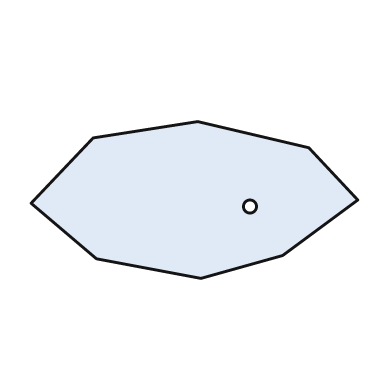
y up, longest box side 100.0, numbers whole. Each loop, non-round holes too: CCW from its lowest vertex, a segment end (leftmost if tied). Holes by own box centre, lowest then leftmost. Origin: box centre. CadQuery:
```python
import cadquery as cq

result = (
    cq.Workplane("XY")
    .moveTo(2.0, -24.0)
    .lineTo(27.0, -17.0)
    .lineTo(50.0, 0.0)
    .lineTo(35.0, 16.0)
    .lineTo(1.0, 24.0)
    .lineTo(-31.0, 19.0)
    .lineTo(-50.0, -1.0)
    .lineTo(-30.0, -18.0)
    .close()
    .moveTo(17.0, -2.0)
    .circle(2.0)
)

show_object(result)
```